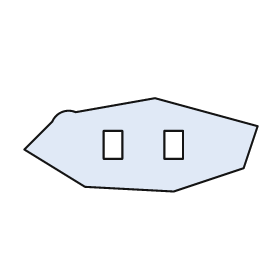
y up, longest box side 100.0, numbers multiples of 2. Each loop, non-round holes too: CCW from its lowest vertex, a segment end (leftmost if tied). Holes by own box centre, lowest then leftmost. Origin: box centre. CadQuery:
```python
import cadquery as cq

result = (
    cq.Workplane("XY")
    .moveTo(14.0, -20.0)
    .lineTo(44.0, -10.0)
    .lineTo(50.0, 8.0)
    .lineTo(6.0, 20.0)
    .lineTo(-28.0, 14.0)
    .threePointArc((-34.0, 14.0), (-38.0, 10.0))
    .lineTo(-50.0, -2.0)
    .lineTo(-24.0, -18.0)
    .close()
    .moveTo(-16.0, -6.0)
    .lineTo(-8.0, -6.0)
    .lineTo(-8.0, 6.0)
    .lineTo(-16.0, 6.0)
    .close()
    .moveTo(10.0, -6.0)
    .lineTo(18.0, -6.0)
    .lineTo(18.0, 6.0)
    .lineTo(10.0, 6.0)
    .close()
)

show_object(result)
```